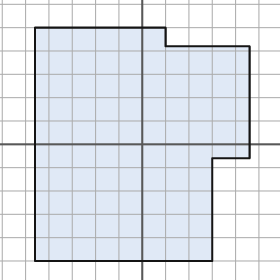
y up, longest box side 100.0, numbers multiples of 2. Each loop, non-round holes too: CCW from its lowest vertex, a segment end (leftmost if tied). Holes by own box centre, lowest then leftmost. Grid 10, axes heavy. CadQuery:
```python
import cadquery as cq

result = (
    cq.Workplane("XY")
    .moveTo(-46.0, -50.0)
    .lineTo(30.0, -50.0)
    .lineTo(30.0, -6.0)
    .lineTo(46.0, -6.0)
    .lineTo(46.0, 42.0)
    .lineTo(10.0, 42.0)
    .lineTo(10.0, 50.0)
    .lineTo(-46.0, 50.0)
    .close()
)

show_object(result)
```